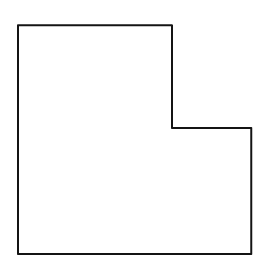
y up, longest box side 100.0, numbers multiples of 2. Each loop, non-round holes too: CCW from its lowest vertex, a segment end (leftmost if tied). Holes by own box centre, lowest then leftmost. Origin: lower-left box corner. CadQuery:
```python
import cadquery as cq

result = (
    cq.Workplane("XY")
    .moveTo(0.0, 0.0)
    .lineTo(100.0, 0.0)
    .lineTo(100.0, 54.0)
    .lineTo(66.0, 54.0)
    .lineTo(66.0, 98.0)
    .lineTo(0.0, 98.0)
    .close()
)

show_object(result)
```